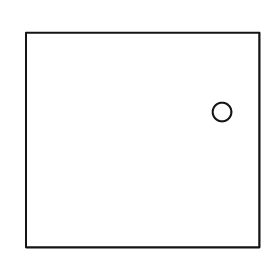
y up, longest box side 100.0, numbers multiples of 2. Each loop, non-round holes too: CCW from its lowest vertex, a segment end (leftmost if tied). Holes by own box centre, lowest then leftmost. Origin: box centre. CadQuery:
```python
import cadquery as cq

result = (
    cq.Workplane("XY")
    .moveTo(-50.0, -46.0)
    .lineTo(50.0, -46.0)
    .lineTo(50.0, 46.0)
    .lineTo(-50.0, 46.0)
    .close()
    .moveTo(34.0, 12.0)
    .circle(4.0)
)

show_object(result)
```